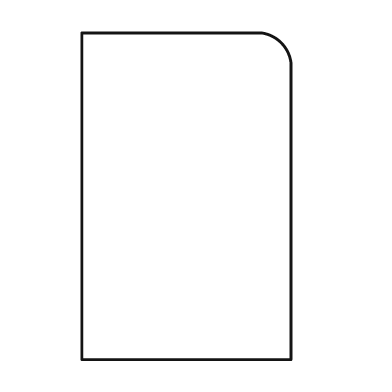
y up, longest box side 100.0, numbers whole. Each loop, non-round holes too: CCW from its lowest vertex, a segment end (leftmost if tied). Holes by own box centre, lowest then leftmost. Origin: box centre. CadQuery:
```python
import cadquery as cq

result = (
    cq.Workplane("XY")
    .moveTo(-32.0, -50.0)
    .lineTo(32.0, -50.0)
    .lineTo(32.0, 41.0)
    .threePointArc((29.0, 47.0), (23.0, 50.0))
    .lineTo(-32.0, 50.0)
    .close()
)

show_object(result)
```